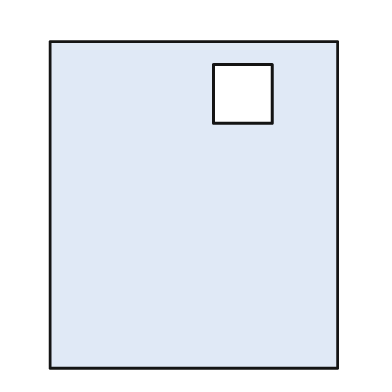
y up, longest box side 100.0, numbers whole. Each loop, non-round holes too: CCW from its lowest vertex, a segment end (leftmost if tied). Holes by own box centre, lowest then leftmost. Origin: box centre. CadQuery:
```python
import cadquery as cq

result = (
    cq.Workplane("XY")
    .moveTo(-44.0, -50.0)
    .lineTo(44.0, -50.0)
    .lineTo(44.0, 50.0)
    .lineTo(-44.0, 50.0)
    .close()
    .moveTo(6.0, 25.0)
    .lineTo(24.0, 25.0)
    .lineTo(24.0, 43.0)
    .lineTo(6.0, 43.0)
    .close()
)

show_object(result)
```